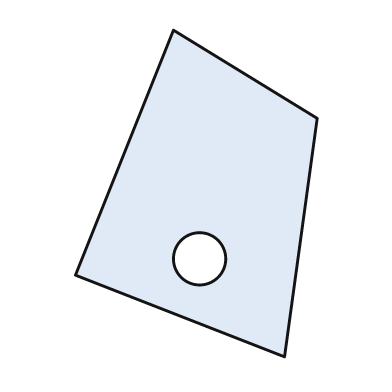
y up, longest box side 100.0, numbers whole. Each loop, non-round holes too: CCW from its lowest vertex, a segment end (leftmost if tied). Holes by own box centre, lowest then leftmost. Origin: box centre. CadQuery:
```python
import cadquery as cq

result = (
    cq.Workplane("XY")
    .moveTo(27.0, -50.0)
    .lineTo(37.0, 23.0)
    .lineTo(-7.0, 50.0)
    .lineTo(-37.0, -25.0)
    .close()
    .moveTo(1.0, -20.0)
    .circle(8.0)
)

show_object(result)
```